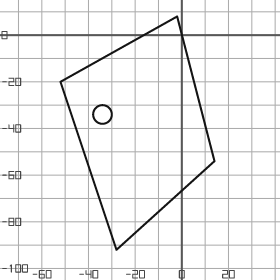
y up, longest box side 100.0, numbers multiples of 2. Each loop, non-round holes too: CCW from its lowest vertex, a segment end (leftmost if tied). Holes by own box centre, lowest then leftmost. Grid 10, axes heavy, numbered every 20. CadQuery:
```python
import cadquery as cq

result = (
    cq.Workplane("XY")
    .moveTo(-28.0, -92.0)
    .lineTo(14.0, -54.0)
    .lineTo(-2.0, 8.0)
    .lineTo(-52.0, -20.0)
    .close()
    .moveTo(-34.0, -34.0)
    .circle(4.0)
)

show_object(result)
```